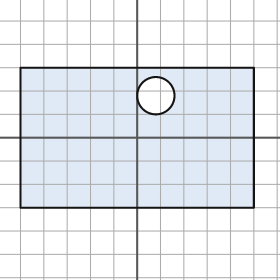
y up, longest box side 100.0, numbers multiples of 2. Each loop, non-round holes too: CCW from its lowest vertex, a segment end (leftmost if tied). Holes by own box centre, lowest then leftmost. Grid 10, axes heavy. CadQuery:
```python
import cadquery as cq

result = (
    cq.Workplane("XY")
    .moveTo(-50.0, -30.0)
    .lineTo(50.0, -30.0)
    .lineTo(50.0, 30.0)
    .lineTo(-50.0, 30.0)
    .close()
    .moveTo(8.0, 18.0)
    .circle(8.0)
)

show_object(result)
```